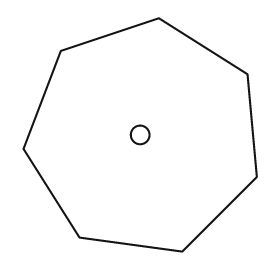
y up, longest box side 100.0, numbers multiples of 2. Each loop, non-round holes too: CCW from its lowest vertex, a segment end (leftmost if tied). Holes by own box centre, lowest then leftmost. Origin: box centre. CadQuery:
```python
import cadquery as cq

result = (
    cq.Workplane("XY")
    .moveTo(18.0, -50.0)
    .lineTo(50.0, -18.0)
    .lineTo(46.0, 26.0)
    .lineTo(8.0, 50.0)
    .lineTo(-34.0, 36.0)
    .lineTo(-50.0, -6.0)
    .lineTo(-26.0, -44.0)
    .close()
    .moveTo(0.0, 0.0)
    .circle(4.0)
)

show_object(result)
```